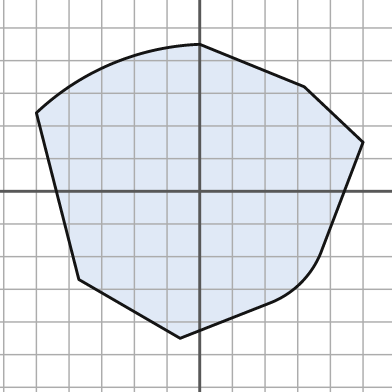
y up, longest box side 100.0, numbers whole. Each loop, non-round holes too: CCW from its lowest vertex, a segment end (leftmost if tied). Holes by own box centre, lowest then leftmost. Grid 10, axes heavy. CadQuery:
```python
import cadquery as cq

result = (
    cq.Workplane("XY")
    .moveTo(-6.0, -45.0)
    .lineTo(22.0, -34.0)
    .threePointArc((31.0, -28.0), (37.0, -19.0))
    .lineTo(50.0, 15.0)
    .lineTo(32.0, 32.0)
    .lineTo(0.0, 45.0)
    .threePointArc((-27.0, 39.0), (-50.0, 24.0))
    .lineTo(-37.0, -27.0)
    .close()
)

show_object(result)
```